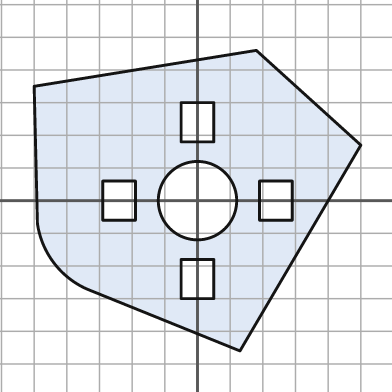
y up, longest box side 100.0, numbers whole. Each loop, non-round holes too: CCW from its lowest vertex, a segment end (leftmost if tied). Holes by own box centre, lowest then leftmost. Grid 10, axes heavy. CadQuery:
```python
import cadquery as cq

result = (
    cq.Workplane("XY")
    .moveTo(13.0, -46.0)
    .lineTo(50.0, 17.0)
    .lineTo(18.0, 46.0)
    .lineTo(-50.0, 35.0)
    .lineTo(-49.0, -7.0)
    .threePointArc((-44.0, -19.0), (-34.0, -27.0))
    .close()
    .moveTo(-5.0, -30.0)
    .lineTo(5.0, -30.0)
    .lineTo(5.0, -18.0)
    .lineTo(-5.0, -18.0)
    .close()
    .moveTo(-29.0, -6.0)
    .lineTo(-19.0, -6.0)
    .lineTo(-19.0, 6.0)
    .lineTo(-29.0, 6.0)
    .close()
    .moveTo(0.0, 0.0)
    .circle(12.0)
    .moveTo(19.0, -6.0)
    .lineTo(29.0, -6.0)
    .lineTo(29.0, 6.0)
    .lineTo(19.0, 6.0)
    .close()
    .moveTo(-5.0, 18.0)
    .lineTo(5.0, 18.0)
    .lineTo(5.0, 30.0)
    .lineTo(-5.0, 30.0)
    .close()
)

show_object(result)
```